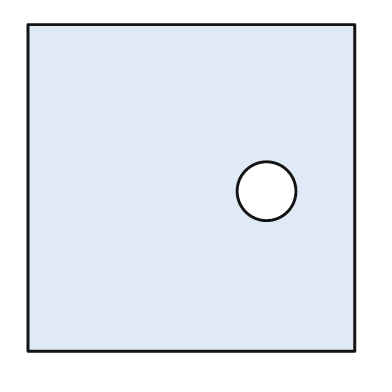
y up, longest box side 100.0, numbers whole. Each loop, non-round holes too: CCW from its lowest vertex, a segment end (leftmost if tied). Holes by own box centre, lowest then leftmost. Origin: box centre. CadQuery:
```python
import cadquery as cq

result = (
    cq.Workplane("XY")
    .moveTo(-50.0, -50.0)
    .lineTo(50.0, -50.0)
    .lineTo(50.0, 50.0)
    .lineTo(-50.0, 50.0)
    .close()
    .moveTo(23.0, -1.0)
    .circle(9.0)
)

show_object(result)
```